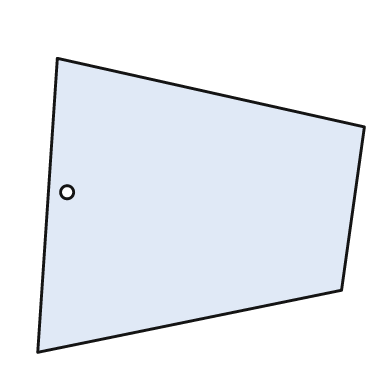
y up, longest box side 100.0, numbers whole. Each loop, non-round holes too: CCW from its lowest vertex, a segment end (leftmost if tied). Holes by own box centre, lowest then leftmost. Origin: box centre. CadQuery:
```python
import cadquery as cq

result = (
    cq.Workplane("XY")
    .moveTo(-50.0, -45.0)
    .lineTo(43.0, -26.0)
    .lineTo(50.0, 24.0)
    .lineTo(-44.0, 45.0)
    .close()
    .moveTo(-41.0, 4.0)
    .circle(2.0)
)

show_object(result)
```